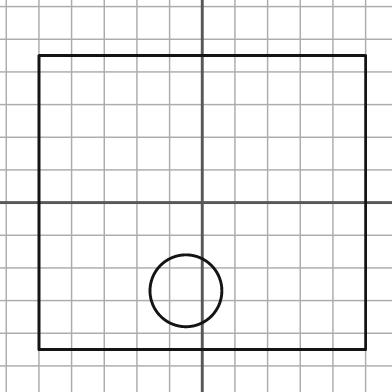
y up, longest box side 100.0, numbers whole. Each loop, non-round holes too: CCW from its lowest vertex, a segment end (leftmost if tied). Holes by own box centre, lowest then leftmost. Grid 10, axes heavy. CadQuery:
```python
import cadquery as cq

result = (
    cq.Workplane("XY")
    .moveTo(-50.0, -45.0)
    .lineTo(50.0, -45.0)
    .lineTo(50.0, 45.0)
    .lineTo(-50.0, 45.0)
    .close()
    .moveTo(-5.0, -27.0)
    .circle(11.0)
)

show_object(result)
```